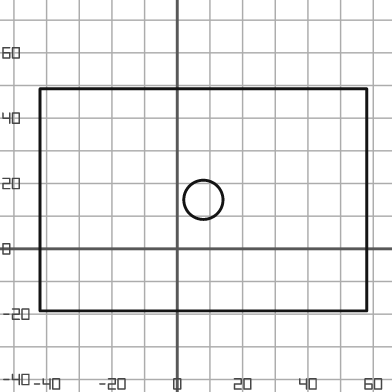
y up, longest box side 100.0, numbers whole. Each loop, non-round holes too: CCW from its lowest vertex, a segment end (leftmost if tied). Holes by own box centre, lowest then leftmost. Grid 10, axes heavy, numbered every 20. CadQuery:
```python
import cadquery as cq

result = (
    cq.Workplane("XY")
    .moveTo(-42.0, -19.0)
    .lineTo(58.0, -19.0)
    .lineTo(58.0, 49.0)
    .lineTo(-42.0, 49.0)
    .close()
    .moveTo(8.0, 15.0)
    .circle(6.0)
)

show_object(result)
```